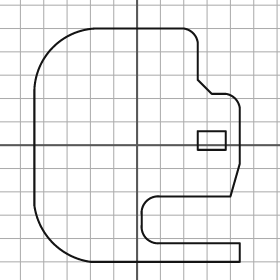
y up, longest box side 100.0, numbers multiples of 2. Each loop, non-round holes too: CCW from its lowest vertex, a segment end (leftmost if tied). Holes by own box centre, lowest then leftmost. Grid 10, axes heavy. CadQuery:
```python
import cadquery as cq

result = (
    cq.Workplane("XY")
    .moveTo(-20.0, -50.0)
    .lineTo(44.0, -50.0)
    .lineTo(44.0, -42.0)
    .lineTo(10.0, -42.0)
    .threePointArc((4.0, -40.0), (2.0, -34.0))
    .lineTo(2.0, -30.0)
    .threePointArc((4.0, -24.0), (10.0, -22.0))
    .lineTo(40.0, -22.0)
    .lineTo(44.0, -8.0)
    .lineTo(44.0, 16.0)
    .threePointArc((42.0, 20.0), (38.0, 22.0))
    .lineTo(32.0, 22.0)
    .lineTo(26.0, 28.0)
    .lineTo(26.0, 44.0)
    .threePointArc((24.0, 48.0), (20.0, 50.0))
    .lineTo(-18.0, 50.0)
    .threePointArc((-36.0, 42.0), (-44.0, 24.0))
    .lineTo(-44.0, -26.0)
    .threePointArc((-36.0, -42.0), (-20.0, -50.0))
    .close()
    .moveTo(26.0, -2.0)
    .lineTo(38.0, -2.0)
    .lineTo(38.0, 6.0)
    .lineTo(26.0, 6.0)
    .close()
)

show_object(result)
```